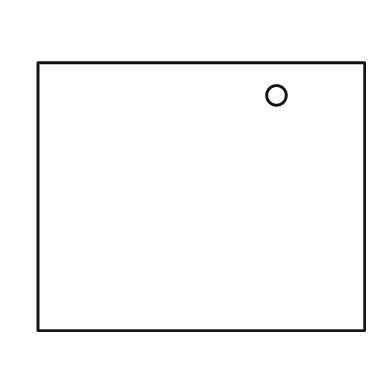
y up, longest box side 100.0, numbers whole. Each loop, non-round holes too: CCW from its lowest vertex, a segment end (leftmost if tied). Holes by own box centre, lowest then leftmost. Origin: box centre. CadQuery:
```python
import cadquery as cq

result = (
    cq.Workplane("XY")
    .moveTo(-50.0, -41.0)
    .lineTo(50.0, -41.0)
    .lineTo(50.0, 41.0)
    .lineTo(-50.0, 41.0)
    .close()
    .moveTo(23.0, 31.0)
    .circle(3.0)
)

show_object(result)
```